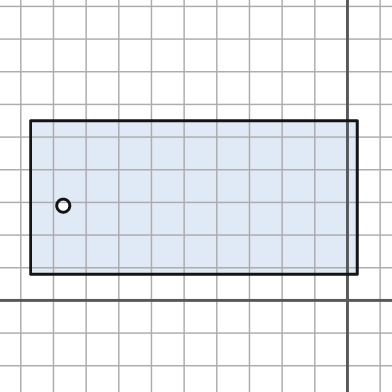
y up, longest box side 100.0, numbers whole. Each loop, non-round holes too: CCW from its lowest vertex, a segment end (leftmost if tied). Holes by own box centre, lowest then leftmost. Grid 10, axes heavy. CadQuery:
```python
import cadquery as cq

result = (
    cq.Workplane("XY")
    .moveTo(-97.0, 8.0)
    .lineTo(3.0, 8.0)
    .lineTo(3.0, 55.0)
    .lineTo(-97.0, 55.0)
    .close()
    .moveTo(-87.0, 29.0)
    .circle(2.0)
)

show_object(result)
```